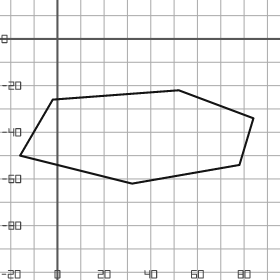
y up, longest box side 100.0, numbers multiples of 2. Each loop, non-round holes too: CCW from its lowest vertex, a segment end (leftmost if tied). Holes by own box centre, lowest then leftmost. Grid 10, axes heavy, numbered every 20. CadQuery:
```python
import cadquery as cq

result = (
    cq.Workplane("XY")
    .moveTo(32.0, -62.0)
    .lineTo(78.0, -54.0)
    .lineTo(84.0, -34.0)
    .lineTo(52.0, -22.0)
    .lineTo(-2.0, -26.0)
    .lineTo(-16.0, -50.0)
    .close()
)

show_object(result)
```